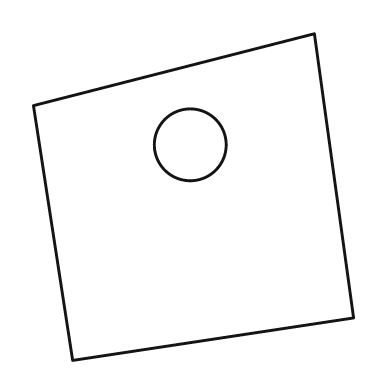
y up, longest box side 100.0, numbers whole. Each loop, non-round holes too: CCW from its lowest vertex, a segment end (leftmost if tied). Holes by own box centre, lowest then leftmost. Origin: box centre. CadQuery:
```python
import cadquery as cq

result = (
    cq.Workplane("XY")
    .moveTo(-37.0, -50.0)
    .lineTo(49.0, -37.0)
    .lineTo(37.0, 50.0)
    .lineTo(-49.0, 28.0)
    .close()
    .moveTo(-1.0, 16.0)
    .circle(11.0)
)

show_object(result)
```